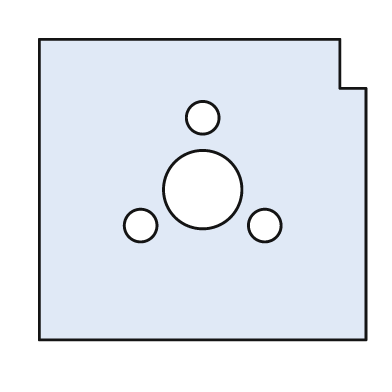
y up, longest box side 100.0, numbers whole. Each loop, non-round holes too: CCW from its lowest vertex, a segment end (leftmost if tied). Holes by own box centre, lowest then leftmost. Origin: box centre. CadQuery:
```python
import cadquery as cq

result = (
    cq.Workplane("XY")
    .moveTo(-50.0, -46.0)
    .lineTo(50.0, -46.0)
    .lineTo(50.0, 31.0)
    .lineTo(42.0, 31.0)
    .lineTo(42.0, 46.0)
    .lineTo(-50.0, 46.0)
    .close()
    .moveTo(-19.0, -11.0)
    .circle(5.0)
    .moveTo(19.0, -11.0)
    .circle(5.0)
    .moveTo(0.0, 0.0)
    .circle(12.0)
    .moveTo(0.0, 22.0)
    .circle(5.0)
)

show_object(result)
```